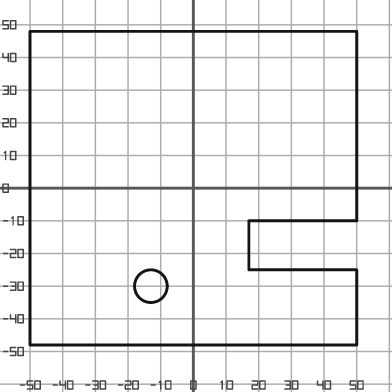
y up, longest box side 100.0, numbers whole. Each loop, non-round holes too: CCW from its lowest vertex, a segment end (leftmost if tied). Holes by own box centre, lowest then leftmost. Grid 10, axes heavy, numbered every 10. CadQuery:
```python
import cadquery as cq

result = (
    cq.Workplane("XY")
    .moveTo(-50.0, -48.0)
    .lineTo(50.0, -48.0)
    .lineTo(50.0, -25.0)
    .lineTo(17.0, -25.0)
    .lineTo(17.0, -10.0)
    .lineTo(50.0, -10.0)
    .lineTo(50.0, 48.0)
    .lineTo(-50.0, 48.0)
    .close()
    .moveTo(-13.0, -30.0)
    .circle(5.0)
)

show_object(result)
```